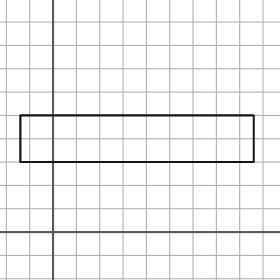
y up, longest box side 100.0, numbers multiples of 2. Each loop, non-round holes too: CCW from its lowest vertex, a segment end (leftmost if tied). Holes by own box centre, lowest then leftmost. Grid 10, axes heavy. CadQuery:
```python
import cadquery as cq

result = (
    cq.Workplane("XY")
    .moveTo(-14.0, 30.0)
    .lineTo(86.0, 30.0)
    .lineTo(86.0, 50.0)
    .lineTo(-14.0, 50.0)
    .close()
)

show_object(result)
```